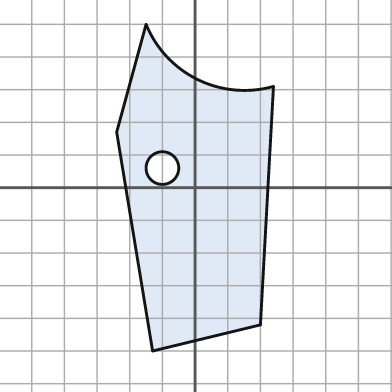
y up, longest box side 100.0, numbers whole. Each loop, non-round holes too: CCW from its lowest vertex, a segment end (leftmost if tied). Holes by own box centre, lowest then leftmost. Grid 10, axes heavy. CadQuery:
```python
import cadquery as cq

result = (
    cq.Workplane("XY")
    .moveTo(-13.0, -50.0)
    .lineTo(20.0, -42.0)
    .lineTo(24.0, 31.0)
    .threePointArc((1.0, 33.0), (-15.0, 50.0))
    .lineTo(-24.0, 17.0)
    .close()
    .moveTo(-10.0, 6.0)
    .circle(5.0)
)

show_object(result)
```